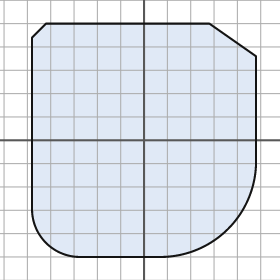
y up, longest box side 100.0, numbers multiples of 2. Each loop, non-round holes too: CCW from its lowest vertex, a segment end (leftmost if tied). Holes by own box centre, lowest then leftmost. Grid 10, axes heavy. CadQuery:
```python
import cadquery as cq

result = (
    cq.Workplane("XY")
    .moveTo(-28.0, -50.0)
    .lineTo(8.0, -50.0)
    .threePointArc((36.0, -38.0), (48.0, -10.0))
    .lineTo(48.0, 36.0)
    .lineTo(28.0, 50.0)
    .lineTo(-42.0, 50.0)
    .lineTo(-48.0, 44.0)
    .lineTo(-48.0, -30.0)
    .threePointArc((-42.0, -44.0), (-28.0, -50.0))
    .close()
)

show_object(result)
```